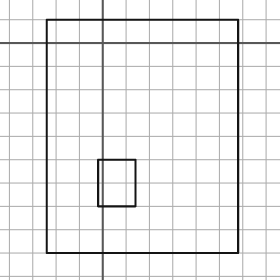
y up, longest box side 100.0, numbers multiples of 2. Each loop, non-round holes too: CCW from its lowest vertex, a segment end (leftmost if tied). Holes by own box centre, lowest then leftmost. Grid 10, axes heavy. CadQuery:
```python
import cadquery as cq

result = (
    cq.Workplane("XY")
    .moveTo(-24.0, -90.0)
    .lineTo(58.0, -90.0)
    .lineTo(58.0, 10.0)
    .lineTo(-24.0, 10.0)
    .close()
    .moveTo(-2.0, -70.0)
    .lineTo(14.0, -70.0)
    .lineTo(14.0, -50.0)
    .lineTo(-2.0, -50.0)
    .close()
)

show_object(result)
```